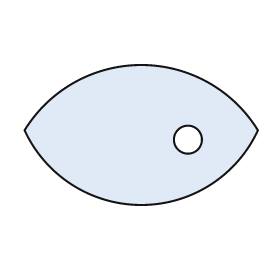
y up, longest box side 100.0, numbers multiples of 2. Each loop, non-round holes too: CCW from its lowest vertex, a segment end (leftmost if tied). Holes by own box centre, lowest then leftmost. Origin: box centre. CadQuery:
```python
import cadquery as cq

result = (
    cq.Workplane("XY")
    .moveTo(-50.0, 2.0)
    .threePointArc((0.0, -30.0), (50.0, 2.0))
    .threePointArc((0.0, 30.0), (-50.0, 2.0))
    .close()
    .moveTo(20.0, -2.0)
    .circle(6.0)
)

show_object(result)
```